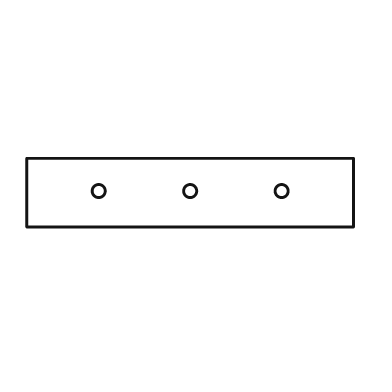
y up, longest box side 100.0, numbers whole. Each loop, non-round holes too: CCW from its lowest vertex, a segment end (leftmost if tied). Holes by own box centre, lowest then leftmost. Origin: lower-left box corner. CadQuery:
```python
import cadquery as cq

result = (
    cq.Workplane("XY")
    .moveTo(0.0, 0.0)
    .lineTo(100.0, 0.0)
    .lineTo(100.0, 21.0)
    .lineTo(0.0, 21.0)
    .close()
    .moveTo(22.0, 11.0)
    .circle(2.0)
    .moveTo(50.0, 11.0)
    .circle(2.0)
    .moveTo(78.0, 11.0)
    .circle(2.0)
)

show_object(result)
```